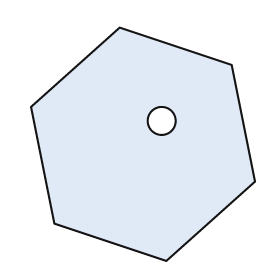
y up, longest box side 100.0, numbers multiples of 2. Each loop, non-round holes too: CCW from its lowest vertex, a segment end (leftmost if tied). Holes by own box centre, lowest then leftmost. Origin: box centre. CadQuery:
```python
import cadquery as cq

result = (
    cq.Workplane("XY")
    .moveTo(10.0, -50.0)
    .lineTo(48.0, -16.0)
    .lineTo(38.0, 34.0)
    .lineTo(-10.0, 50.0)
    .lineTo(-48.0, 16.0)
    .lineTo(-38.0, -34.0)
    .close()
    .moveTo(8.0, 10.0)
    .circle(6.0)
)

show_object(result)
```